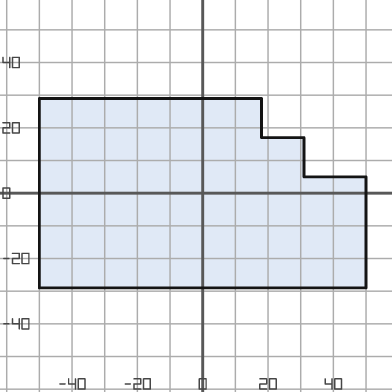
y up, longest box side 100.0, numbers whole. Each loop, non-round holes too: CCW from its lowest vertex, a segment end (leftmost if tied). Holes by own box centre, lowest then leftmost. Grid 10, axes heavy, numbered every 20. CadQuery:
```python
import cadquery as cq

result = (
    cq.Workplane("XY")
    .moveTo(-50.0, -29.0)
    .lineTo(50.0, -29.0)
    .lineTo(50.0, 5.0)
    .lineTo(31.0, 5.0)
    .lineTo(31.0, 17.0)
    .lineTo(18.0, 17.0)
    .lineTo(18.0, 29.0)
    .lineTo(-50.0, 29.0)
    .close()
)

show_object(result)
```